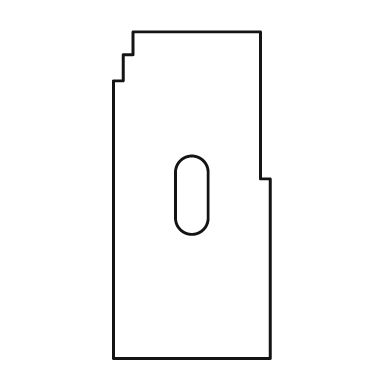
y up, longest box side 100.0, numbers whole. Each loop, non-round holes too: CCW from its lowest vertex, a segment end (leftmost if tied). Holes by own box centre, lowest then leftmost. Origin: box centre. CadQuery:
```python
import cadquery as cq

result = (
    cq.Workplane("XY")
    .moveTo(-24.0, -50.0)
    .lineTo(24.0, -50.0)
    .lineTo(24.0, 5.0)
    .lineTo(21.0, 5.0)
    .lineTo(21.0, 50.0)
    .lineTo(-18.0, 50.0)
    .lineTo(-18.0, 43.0)
    .lineTo(-21.0, 43.0)
    .lineTo(-21.0, 35.0)
    .lineTo(-24.0, 35.0)
    .close()
    .moveTo(-5.0, -7.0)
    .threePointArc((0.0, -12.0), (5.0, -7.0))
    .lineTo(5.0, 7.0)
    .threePointArc((0.0, 12.0), (-5.0, 7.0))
    .close()
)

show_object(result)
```